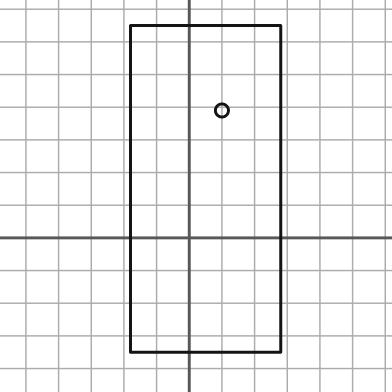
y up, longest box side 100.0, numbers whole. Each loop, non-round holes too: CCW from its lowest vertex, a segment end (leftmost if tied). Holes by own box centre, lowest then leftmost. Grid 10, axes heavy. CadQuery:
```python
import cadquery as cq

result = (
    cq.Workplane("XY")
    .moveTo(-18.0, -35.0)
    .lineTo(28.0, -35.0)
    .lineTo(28.0, 65.0)
    .lineTo(-18.0, 65.0)
    .close()
    .moveTo(10.0, 39.0)
    .circle(2.0)
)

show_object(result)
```